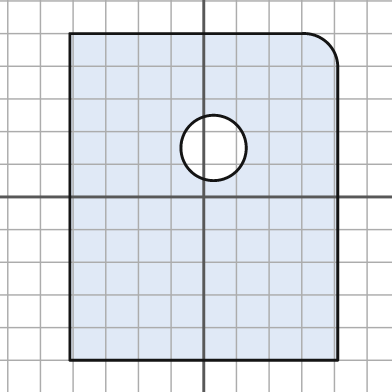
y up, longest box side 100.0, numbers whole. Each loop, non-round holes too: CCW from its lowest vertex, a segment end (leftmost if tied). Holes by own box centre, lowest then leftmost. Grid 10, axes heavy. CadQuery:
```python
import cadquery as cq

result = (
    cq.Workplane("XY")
    .moveTo(-41.0, -50.0)
    .lineTo(41.0, -50.0)
    .lineTo(41.0, 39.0)
    .threePointArc((38.0, 47.0), (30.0, 50.0))
    .lineTo(-41.0, 50.0)
    .close()
    .moveTo(3.0, 15.0)
    .circle(10.0)
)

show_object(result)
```